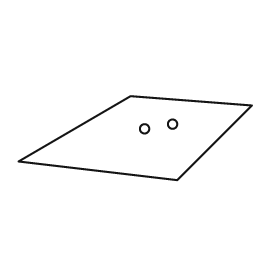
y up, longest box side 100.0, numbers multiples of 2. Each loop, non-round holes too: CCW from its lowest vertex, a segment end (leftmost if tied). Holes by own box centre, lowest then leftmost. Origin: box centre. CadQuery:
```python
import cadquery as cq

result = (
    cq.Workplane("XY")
    .moveTo(18.0, -18.0)
    .lineTo(50.0, 14.0)
    .lineTo(-2.0, 18.0)
    .lineTo(-50.0, -10.0)
    .close()
    .moveTo(4.0, 4.0)
    .circle(2.0)
    .moveTo(16.0, 6.0)
    .circle(2.0)
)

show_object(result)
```